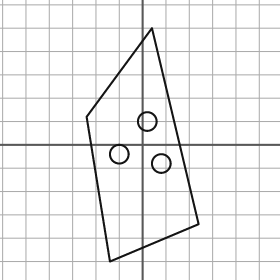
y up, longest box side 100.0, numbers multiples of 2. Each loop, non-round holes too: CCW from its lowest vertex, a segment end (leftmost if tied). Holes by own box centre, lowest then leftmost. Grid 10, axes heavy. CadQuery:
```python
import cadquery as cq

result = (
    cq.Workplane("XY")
    .moveTo(-14.0, -50.0)
    .lineTo(24.0, -34.0)
    .lineTo(4.0, 50.0)
    .lineTo(-24.0, 12.0)
    .close()
    .moveTo(8.0, -8.0)
    .circle(4.0)
    .moveTo(-10.0, -4.0)
    .circle(4.0)
    .moveTo(2.0, 10.0)
    .circle(4.0)
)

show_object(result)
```